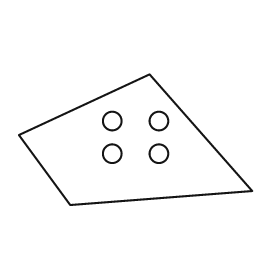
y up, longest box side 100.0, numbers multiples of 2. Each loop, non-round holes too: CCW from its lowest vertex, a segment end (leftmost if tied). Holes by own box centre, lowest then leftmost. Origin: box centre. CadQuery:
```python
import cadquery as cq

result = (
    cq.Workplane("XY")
    .moveTo(-28.0, -28.0)
    .lineTo(50.0, -22.0)
    .lineTo(6.0, 28.0)
    .lineTo(-50.0, 2.0)
    .close()
    .moveTo(-10.0, -6.0)
    .circle(4.0)
    .moveTo(10.0, -6.0)
    .circle(4.0)
    .moveTo(-10.0, 8.0)
    .circle(4.0)
    .moveTo(10.0, 8.0)
    .circle(4.0)
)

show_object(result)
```